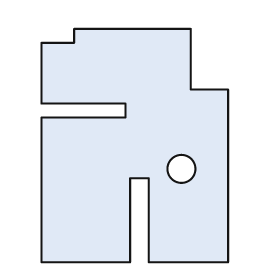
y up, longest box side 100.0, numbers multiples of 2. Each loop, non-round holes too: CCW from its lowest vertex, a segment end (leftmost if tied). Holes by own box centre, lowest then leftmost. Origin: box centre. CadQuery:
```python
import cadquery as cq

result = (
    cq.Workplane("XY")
    .moveTo(-40.0, -50.0)
    .lineTo(-2.0, -50.0)
    .lineTo(-2.0, -14.0)
    .lineTo(6.0, -14.0)
    .lineTo(6.0, -50.0)
    .lineTo(40.0, -50.0)
    .lineTo(40.0, 24.0)
    .lineTo(24.0, 24.0)
    .lineTo(24.0, 50.0)
    .lineTo(-26.0, 50.0)
    .lineTo(-26.0, 44.0)
    .lineTo(-40.0, 44.0)
    .lineTo(-40.0, 18.0)
    .lineTo(-4.0, 18.0)
    .lineTo(-4.0, 12.0)
    .lineTo(-40.0, 12.0)
    .close()
    .moveTo(20.0, -10.0)
    .circle(6.0)
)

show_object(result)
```